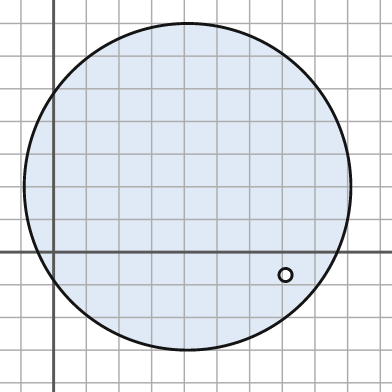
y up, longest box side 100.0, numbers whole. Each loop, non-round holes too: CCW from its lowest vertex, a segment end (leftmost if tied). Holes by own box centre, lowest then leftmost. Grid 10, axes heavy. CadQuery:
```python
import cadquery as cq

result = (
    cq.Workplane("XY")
    .moveTo(41.0, 20.0)
    .circle(50.0)
    .moveTo(71.0, -7.0)
    .circle(2.0)
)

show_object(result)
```